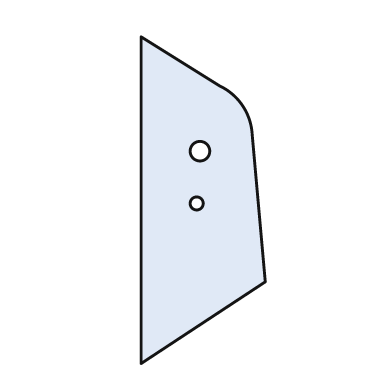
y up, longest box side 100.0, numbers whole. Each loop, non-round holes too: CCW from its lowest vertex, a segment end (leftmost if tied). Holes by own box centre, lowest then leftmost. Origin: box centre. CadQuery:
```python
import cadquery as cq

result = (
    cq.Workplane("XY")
    .moveTo(-19.0, -50.0)
    .lineTo(19.0, -25.0)
    .lineTo(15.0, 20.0)
    .threePointArc((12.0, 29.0), (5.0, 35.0))
    .lineTo(-19.0, 50.0)
    .close()
    .moveTo(-2.0, -1.0)
    .circle(2.0)
    .moveTo(-1.0, 15.0)
    .circle(3.0)
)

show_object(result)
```